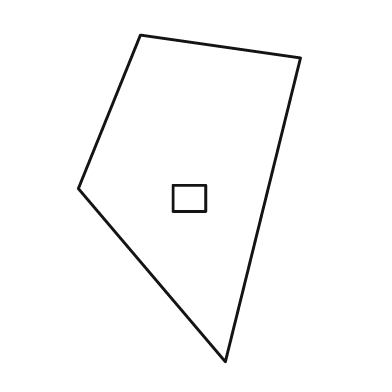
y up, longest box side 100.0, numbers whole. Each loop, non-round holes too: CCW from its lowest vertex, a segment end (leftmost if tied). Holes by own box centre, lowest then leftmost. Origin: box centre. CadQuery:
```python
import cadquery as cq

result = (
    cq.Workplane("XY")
    .moveTo(11.0, -50.0)
    .lineTo(34.0, 43.0)
    .lineTo(-15.0, 50.0)
    .lineTo(-34.0, 3.0)
    .close()
    .moveTo(-5.0, -4.0)
    .lineTo(5.0, -4.0)
    .lineTo(5.0, 4.0)
    .lineTo(-5.0, 4.0)
    .close()
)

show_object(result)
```